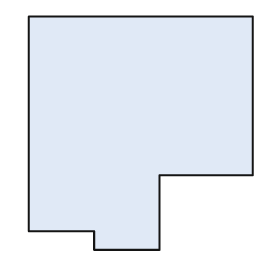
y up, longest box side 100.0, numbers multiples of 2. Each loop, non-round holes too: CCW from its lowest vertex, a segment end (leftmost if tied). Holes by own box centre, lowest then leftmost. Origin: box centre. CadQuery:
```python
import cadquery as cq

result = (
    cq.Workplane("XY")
    .moveTo(-20.0, -50.0)
    .lineTo(8.0, -50.0)
    .lineTo(8.0, -18.0)
    .lineTo(48.0, -18.0)
    .lineTo(48.0, 50.0)
    .lineTo(-48.0, 50.0)
    .lineTo(-48.0, -42.0)
    .lineTo(-20.0, -42.0)
    .close()
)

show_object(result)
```